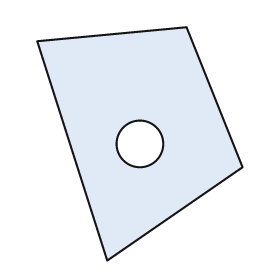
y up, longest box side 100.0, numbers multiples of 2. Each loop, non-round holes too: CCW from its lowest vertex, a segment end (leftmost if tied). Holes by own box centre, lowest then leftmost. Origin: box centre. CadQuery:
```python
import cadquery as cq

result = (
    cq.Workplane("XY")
    .moveTo(-14.0, -50.0)
    .lineTo(44.0, -10.0)
    .lineTo(20.0, 50.0)
    .lineTo(-44.0, 44.0)
    .close()
    .moveTo(0.0, 0.0)
    .circle(10.0)
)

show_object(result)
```